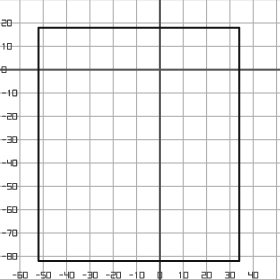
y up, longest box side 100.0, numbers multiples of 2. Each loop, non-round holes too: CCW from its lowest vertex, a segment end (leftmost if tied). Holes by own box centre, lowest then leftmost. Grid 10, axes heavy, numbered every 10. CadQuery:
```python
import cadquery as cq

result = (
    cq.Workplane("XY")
    .moveTo(-52.0, -82.0)
    .lineTo(34.0, -82.0)
    .lineTo(34.0, 18.0)
    .lineTo(-52.0, 18.0)
    .close()
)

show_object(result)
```